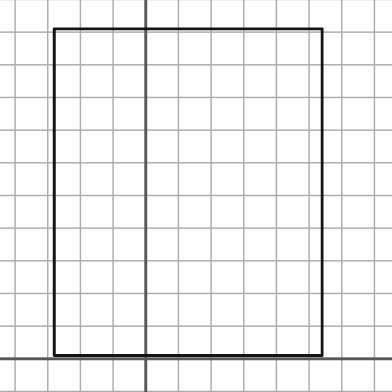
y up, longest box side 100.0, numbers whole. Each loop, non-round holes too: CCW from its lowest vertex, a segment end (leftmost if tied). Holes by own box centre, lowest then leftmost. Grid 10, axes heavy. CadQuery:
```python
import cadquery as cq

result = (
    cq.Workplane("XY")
    .moveTo(-28.0, 1.0)
    .lineTo(54.0, 1.0)
    .lineTo(54.0, 101.0)
    .lineTo(-28.0, 101.0)
    .close()
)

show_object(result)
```